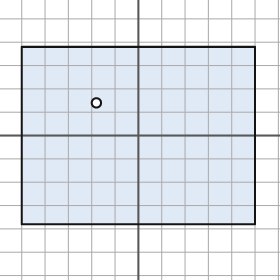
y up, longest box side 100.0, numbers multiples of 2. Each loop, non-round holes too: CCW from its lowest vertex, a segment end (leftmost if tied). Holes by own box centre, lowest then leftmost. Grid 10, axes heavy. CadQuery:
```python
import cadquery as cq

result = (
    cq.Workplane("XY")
    .moveTo(-50.0, -38.0)
    .lineTo(50.0, -38.0)
    .lineTo(50.0, 38.0)
    .lineTo(-50.0, 38.0)
    .close()
    .moveTo(-18.0, 14.0)
    .circle(2.0)
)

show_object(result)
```